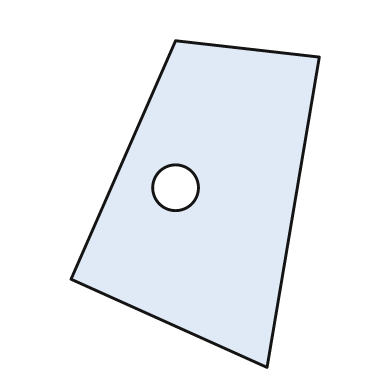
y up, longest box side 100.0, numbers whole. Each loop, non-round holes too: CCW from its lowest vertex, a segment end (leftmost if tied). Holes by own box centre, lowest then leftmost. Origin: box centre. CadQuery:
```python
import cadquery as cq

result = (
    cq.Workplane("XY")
    .moveTo(22.0, -50.0)
    .lineTo(38.0, 45.0)
    .lineTo(-6.0, 50.0)
    .lineTo(-38.0, -23.0)
    .close()
    .moveTo(-6.0, 5.0)
    .circle(7.0)
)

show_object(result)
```